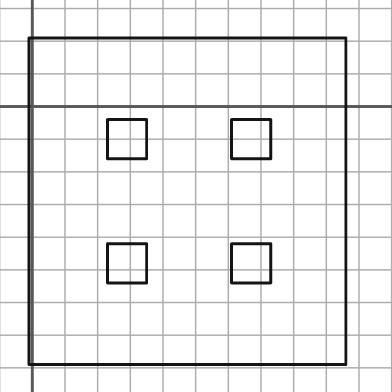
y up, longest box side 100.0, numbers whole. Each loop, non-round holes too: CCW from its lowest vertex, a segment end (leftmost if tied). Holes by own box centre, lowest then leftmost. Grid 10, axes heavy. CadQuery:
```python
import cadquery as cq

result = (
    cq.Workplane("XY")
    .moveTo(-1.0, -79.0)
    .lineTo(96.0, -79.0)
    .lineTo(96.0, 21.0)
    .lineTo(-1.0, 21.0)
    .close()
    .moveTo(23.0, -54.0)
    .lineTo(35.0, -54.0)
    .lineTo(35.0, -42.0)
    .lineTo(23.0, -42.0)
    .close()
    .moveTo(61.0, -54.0)
    .lineTo(73.0, -54.0)
    .lineTo(73.0, -42.0)
    .lineTo(61.0, -42.0)
    .close()
    .moveTo(23.0, -16.0)
    .lineTo(35.0, -16.0)
    .lineTo(35.0, -4.0)
    .lineTo(23.0, -4.0)
    .close()
    .moveTo(61.0, -16.0)
    .lineTo(73.0, -16.0)
    .lineTo(73.0, -4.0)
    .lineTo(61.0, -4.0)
    .close()
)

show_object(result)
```